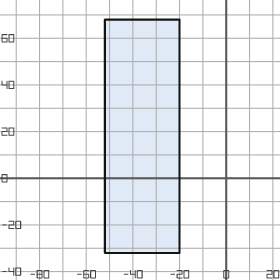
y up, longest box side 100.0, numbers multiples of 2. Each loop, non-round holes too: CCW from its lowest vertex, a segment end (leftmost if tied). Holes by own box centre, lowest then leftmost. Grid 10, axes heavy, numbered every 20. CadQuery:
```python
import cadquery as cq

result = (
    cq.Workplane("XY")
    .moveTo(-52.0, -32.0)
    .lineTo(-20.0, -32.0)
    .lineTo(-20.0, 68.0)
    .lineTo(-52.0, 68.0)
    .close()
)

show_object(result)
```